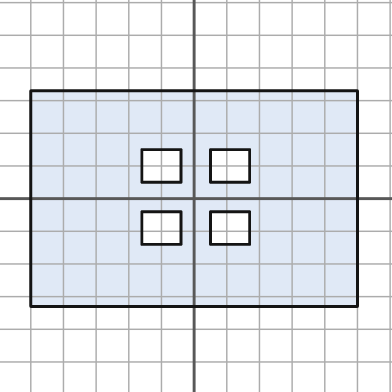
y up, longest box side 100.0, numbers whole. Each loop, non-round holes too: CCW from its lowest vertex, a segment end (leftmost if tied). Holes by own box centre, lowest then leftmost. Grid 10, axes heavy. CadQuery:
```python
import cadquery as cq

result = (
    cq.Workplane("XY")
    .moveTo(-50.0, -33.0)
    .lineTo(50.0, -33.0)
    .lineTo(50.0, 33.0)
    .lineTo(-50.0, 33.0)
    .close()
    .moveTo(-16.0, -14.0)
    .lineTo(-4.0, -14.0)
    .lineTo(-4.0, -4.0)
    .lineTo(-16.0, -4.0)
    .close()
    .moveTo(5.0, -14.0)
    .lineTo(17.0, -14.0)
    .lineTo(17.0, -4.0)
    .lineTo(5.0, -4.0)
    .close()
    .moveTo(-16.0, 5.0)
    .lineTo(-4.0, 5.0)
    .lineTo(-4.0, 15.0)
    .lineTo(-16.0, 15.0)
    .close()
    .moveTo(5.0, 5.0)
    .lineTo(17.0, 5.0)
    .lineTo(17.0, 15.0)
    .lineTo(5.0, 15.0)
    .close()
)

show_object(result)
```